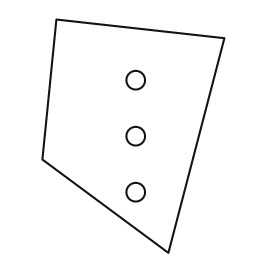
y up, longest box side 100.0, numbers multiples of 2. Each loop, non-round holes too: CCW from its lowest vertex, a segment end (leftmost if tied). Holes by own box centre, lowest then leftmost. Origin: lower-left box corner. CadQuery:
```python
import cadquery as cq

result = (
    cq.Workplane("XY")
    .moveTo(54.0, 0.0)
    .lineTo(78.0, 92.0)
    .lineTo(6.0, 100.0)
    .lineTo(0.0, 40.0)
    .close()
    .moveTo(40.0, 26.0)
    .circle(4.0)
    .moveTo(40.0, 50.0)
    .circle(4.0)
    .moveTo(40.0, 74.0)
    .circle(4.0)
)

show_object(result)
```